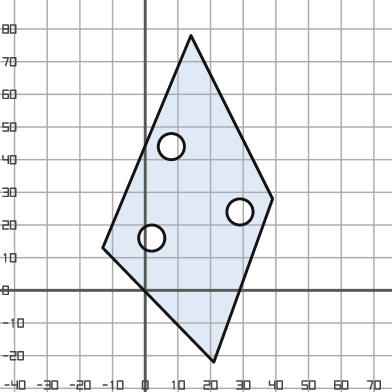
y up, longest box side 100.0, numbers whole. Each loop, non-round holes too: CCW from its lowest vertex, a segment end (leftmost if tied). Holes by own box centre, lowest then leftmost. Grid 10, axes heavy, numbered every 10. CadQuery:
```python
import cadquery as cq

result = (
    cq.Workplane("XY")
    .moveTo(21.0, -22.0)
    .lineTo(39.0, 28.0)
    .lineTo(14.0, 78.0)
    .lineTo(-13.0, 13.0)
    .close()
    .moveTo(2.0, 16.0)
    .circle(4.0)
    .moveTo(29.0, 24.0)
    .circle(4.0)
    .moveTo(8.0, 44.0)
    .circle(4.0)
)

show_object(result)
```